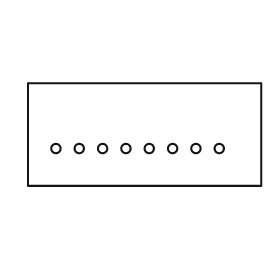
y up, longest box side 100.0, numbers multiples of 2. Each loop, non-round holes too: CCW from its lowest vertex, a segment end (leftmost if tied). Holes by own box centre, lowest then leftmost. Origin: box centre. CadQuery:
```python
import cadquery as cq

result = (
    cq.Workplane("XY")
    .moveTo(-50.0, -22.0)
    .lineTo(50.0, -22.0)
    .lineTo(50.0, 22.0)
    .lineTo(-50.0, 22.0)
    .close()
    .moveTo(-38.0, -6.0)
    .circle(2.0)
    .moveTo(-28.0, -6.0)
    .circle(2.0)
    .moveTo(-18.0, -6.0)
    .circle(2.0)
    .moveTo(-8.0, -6.0)
    .circle(2.0)
    .moveTo(2.0, -6.0)
    .circle(2.0)
    .moveTo(12.0, -6.0)
    .circle(2.0)
    .moveTo(22.0, -6.0)
    .circle(2.0)
    .moveTo(32.0, -6.0)
    .circle(2.0)
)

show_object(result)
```